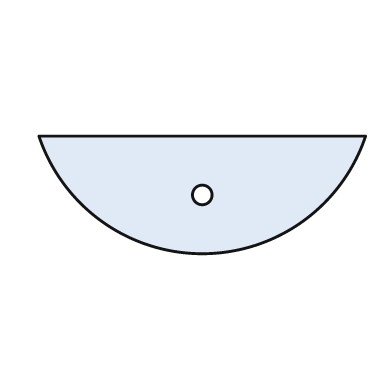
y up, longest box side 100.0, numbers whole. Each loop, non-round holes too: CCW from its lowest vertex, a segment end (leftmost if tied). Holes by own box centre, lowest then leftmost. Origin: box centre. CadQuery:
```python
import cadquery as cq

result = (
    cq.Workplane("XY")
    .moveTo(-50.0, 18.0)
    .threePointArc((0.0, -18.0), (50.0, 18.0))
    .close()
    .moveTo(0.0, 0.0)
    .circle(3.0)
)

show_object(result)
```